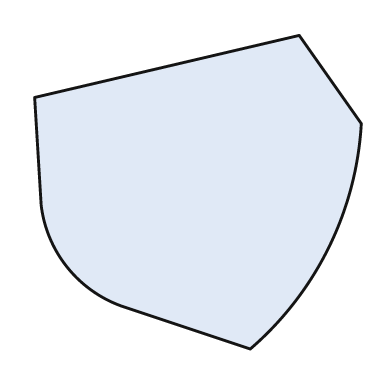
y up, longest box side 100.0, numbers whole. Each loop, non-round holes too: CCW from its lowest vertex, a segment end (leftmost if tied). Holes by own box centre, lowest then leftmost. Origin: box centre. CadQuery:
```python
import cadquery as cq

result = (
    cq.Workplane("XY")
    .moveTo(16.0, -48.0)
    .threePointArc((40.0, -17.0), (50.0, 21.0))
    .lineTo(31.0, 48.0)
    .lineTo(-50.0, 29.0)
    .lineTo(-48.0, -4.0)
    .threePointArc((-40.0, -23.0), (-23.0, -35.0))
    .close()
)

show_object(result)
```